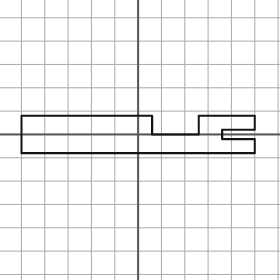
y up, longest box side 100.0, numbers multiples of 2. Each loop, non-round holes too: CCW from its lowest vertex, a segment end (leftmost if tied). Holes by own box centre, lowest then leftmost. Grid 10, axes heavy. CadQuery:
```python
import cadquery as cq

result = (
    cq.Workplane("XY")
    .moveTo(-50.0, -8.0)
    .lineTo(50.0, -8.0)
    .lineTo(50.0, -2.0)
    .lineTo(36.0, -2.0)
    .lineTo(36.0, 2.0)
    .lineTo(50.0, 2.0)
    .lineTo(50.0, 8.0)
    .lineTo(26.0, 8.0)
    .lineTo(26.0, 0.0)
    .lineTo(6.0, 0.0)
    .lineTo(6.0, 8.0)
    .lineTo(-50.0, 8.0)
    .close()
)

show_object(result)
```